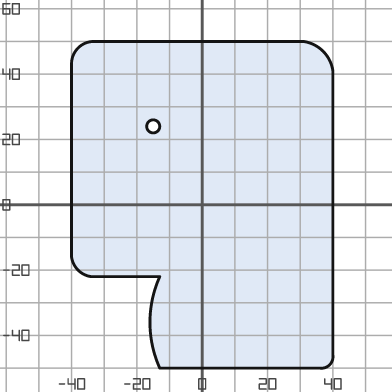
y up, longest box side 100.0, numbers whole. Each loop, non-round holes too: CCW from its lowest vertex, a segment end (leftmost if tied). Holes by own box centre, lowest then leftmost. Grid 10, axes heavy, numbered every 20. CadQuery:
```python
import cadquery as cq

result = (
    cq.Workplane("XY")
    .moveTo(-13.0, -50.0)
    .lineTo(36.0, -50.0)
    .threePointArc((39.0, -49.0), (40.0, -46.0))
    .lineTo(40.0, 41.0)
    .threePointArc((37.0, 47.0), (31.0, 50.0))
    .lineTo(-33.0, 50.0)
    .threePointArc((-38.0, 48.0), (-40.0, 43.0))
    .lineTo(-40.0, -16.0)
    .threePointArc((-38.0, -20.0), (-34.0, -22.0))
    .lineTo(-13.0, -22.0)
    .threePointArc((-16.0, -36.0), (-13.0, -50.0))
    .close()
    .moveTo(-15.0, 24.0)
    .circle(2.0)
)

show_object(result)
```